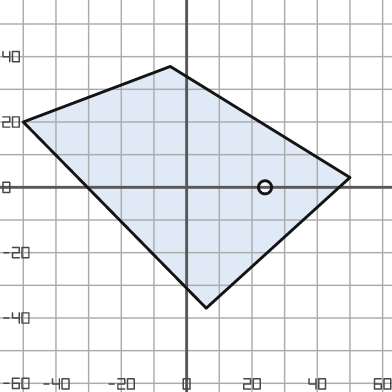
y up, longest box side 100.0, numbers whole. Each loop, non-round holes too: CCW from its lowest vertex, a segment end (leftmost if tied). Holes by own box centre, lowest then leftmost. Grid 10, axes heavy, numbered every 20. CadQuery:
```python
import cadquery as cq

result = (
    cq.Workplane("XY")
    .moveTo(6.0, -37.0)
    .lineTo(50.0, 3.0)
    .lineTo(-5.0, 37.0)
    .lineTo(-50.0, 20.0)
    .close()
    .moveTo(24.0, 0.0)
    .circle(2.0)
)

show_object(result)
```